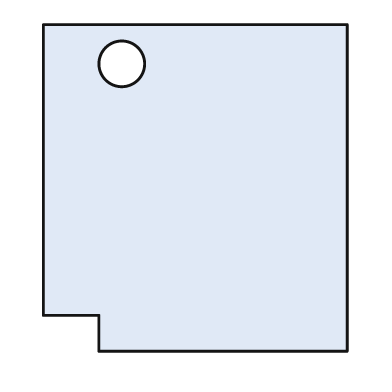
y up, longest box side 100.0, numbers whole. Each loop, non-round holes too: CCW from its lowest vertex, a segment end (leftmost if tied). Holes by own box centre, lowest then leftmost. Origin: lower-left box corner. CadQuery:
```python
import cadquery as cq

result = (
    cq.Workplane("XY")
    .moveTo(17.0, 0.0)
    .lineTo(93.0, 0.0)
    .lineTo(93.0, 100.0)
    .lineTo(0.0, 100.0)
    .lineTo(0.0, 11.0)
    .lineTo(17.0, 11.0)
    .close()
    .moveTo(24.0, 88.0)
    .circle(7.0)
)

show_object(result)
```